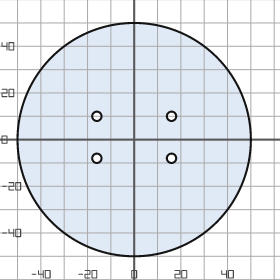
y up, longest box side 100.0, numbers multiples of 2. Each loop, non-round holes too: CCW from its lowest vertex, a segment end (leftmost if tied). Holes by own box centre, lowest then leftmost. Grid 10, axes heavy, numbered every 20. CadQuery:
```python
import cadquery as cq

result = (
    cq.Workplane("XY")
    .moveTo(0.0, 0.0)
    .circle(50.0)
    .moveTo(-16.0, -8.0)
    .circle(2.0)
    .moveTo(16.0, -8.0)
    .circle(2.0)
    .moveTo(-16.0, 10.0)
    .circle(2.0)
    .moveTo(16.0, 10.0)
    .circle(2.0)
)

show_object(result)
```